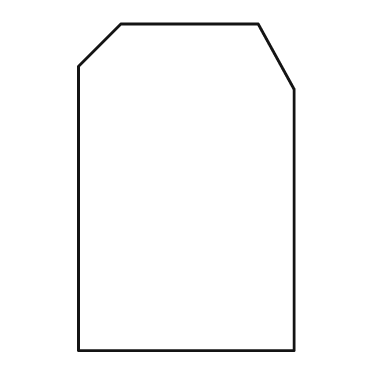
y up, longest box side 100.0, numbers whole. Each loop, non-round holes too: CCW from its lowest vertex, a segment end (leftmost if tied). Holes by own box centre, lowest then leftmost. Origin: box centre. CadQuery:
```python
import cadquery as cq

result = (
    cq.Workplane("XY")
    .moveTo(-33.0, -50.0)
    .lineTo(33.0, -50.0)
    .lineTo(33.0, 30.0)
    .lineTo(22.0, 50.0)
    .lineTo(-20.0, 50.0)
    .lineTo(-33.0, 37.0)
    .close()
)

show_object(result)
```